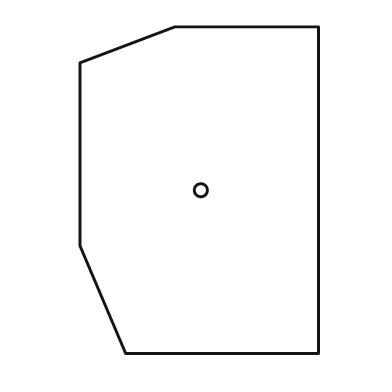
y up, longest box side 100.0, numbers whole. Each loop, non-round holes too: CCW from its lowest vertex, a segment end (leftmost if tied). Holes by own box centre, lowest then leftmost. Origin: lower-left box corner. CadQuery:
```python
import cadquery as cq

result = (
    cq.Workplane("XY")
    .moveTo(14.0, 0.0)
    .lineTo(73.0, 0.0)
    .lineTo(73.0, 100.0)
    .lineTo(29.0, 100.0)
    .lineTo(0.0, 89.0)
    .lineTo(0.0, 33.0)
    .close()
    .moveTo(37.0, 50.0)
    .circle(2.0)
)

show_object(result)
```